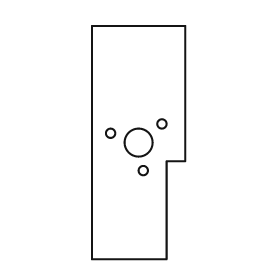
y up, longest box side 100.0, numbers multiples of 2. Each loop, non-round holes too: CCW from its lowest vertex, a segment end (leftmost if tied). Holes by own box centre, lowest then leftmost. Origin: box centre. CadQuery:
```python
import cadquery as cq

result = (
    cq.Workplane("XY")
    .moveTo(-20.0, -50.0)
    .lineTo(12.0, -50.0)
    .lineTo(12.0, -8.0)
    .lineTo(20.0, -8.0)
    .lineTo(20.0, 50.0)
    .lineTo(-20.0, 50.0)
    .close()
    .moveTo(2.0, -12.0)
    .circle(2.0)
    .moveTo(0.0, 0.0)
    .circle(6.0)
    .moveTo(-12.0, 4.0)
    .circle(2.0)
    .moveTo(10.0, 8.0)
    .circle(2.0)
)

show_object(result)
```